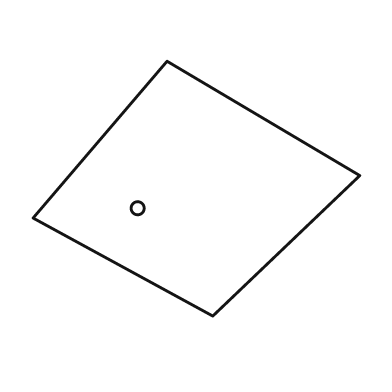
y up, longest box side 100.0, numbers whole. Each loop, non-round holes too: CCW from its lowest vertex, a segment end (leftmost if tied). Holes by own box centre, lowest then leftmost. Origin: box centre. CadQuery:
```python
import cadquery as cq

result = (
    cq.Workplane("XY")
    .moveTo(5.0, -39.0)
    .lineTo(50.0, 4.0)
    .lineTo(-9.0, 39.0)
    .lineTo(-50.0, -9.0)
    .close()
    .moveTo(-18.0, -6.0)
    .circle(2.0)
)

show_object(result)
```